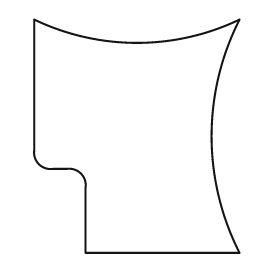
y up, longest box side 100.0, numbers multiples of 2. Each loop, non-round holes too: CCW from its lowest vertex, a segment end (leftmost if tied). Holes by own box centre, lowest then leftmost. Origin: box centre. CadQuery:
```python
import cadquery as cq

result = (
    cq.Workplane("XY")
    .moveTo(-22.0, -50.0)
    .lineTo(44.0, -50.0)
    .threePointArc((32.0, 0.0), (44.0, 50.0))
    .threePointArc((0.0, 40.0), (-44.0, 50.0))
    .lineTo(-44.0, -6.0)
    .threePointArc((-42.0, -12.0), (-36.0, -14.0))
    .lineTo(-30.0, -14.0)
    .threePointArc((-24.0, -16.0), (-22.0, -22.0))
    .close()
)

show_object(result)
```